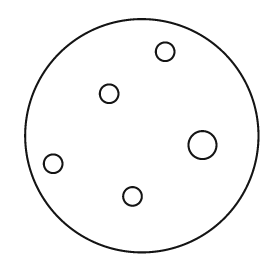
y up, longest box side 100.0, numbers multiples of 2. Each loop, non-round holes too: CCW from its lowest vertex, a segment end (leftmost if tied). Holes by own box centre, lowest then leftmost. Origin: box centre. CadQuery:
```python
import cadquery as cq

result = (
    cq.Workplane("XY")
    .moveTo(0.0, 0.0)
    .circle(50.0)
    .moveTo(-4.0, -26.0)
    .circle(4.0)
    .moveTo(-38.0, -12.0)
    .circle(4.0)
    .moveTo(26.0, -4.0)
    .circle(6.0)
    .moveTo(-14.0, 18.0)
    .circle(4.0)
    .moveTo(10.0, 36.0)
    .circle(4.0)
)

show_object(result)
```